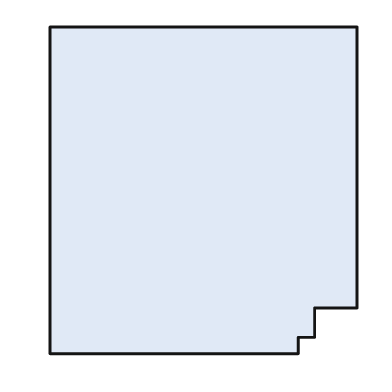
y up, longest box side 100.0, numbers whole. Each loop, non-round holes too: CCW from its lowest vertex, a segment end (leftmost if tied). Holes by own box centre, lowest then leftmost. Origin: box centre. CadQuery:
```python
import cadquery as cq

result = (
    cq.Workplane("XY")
    .moveTo(-47.0, -50.0)
    .lineTo(29.0, -50.0)
    .lineTo(29.0, -45.0)
    .lineTo(34.0, -45.0)
    .lineTo(34.0, -36.0)
    .lineTo(47.0, -36.0)
    .lineTo(47.0, 50.0)
    .lineTo(-47.0, 50.0)
    .close()
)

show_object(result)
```